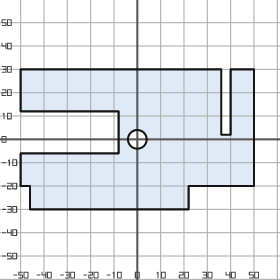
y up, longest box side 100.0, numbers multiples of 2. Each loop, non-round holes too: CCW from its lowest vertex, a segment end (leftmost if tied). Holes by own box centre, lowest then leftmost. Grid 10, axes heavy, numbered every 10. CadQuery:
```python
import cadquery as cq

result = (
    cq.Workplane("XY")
    .moveTo(-46.0, -30.0)
    .lineTo(22.0, -30.0)
    .lineTo(22.0, -20.0)
    .lineTo(50.0, -20.0)
    .lineTo(50.0, 30.0)
    .lineTo(40.0, 30.0)
    .lineTo(40.0, 2.0)
    .lineTo(36.0, 2.0)
    .lineTo(36.0, 30.0)
    .lineTo(-50.0, 30.0)
    .lineTo(-50.0, 12.0)
    .lineTo(-8.0, 12.0)
    .lineTo(-8.0, -6.0)
    .lineTo(-50.0, -6.0)
    .lineTo(-50.0, -20.0)
    .lineTo(-46.0, -20.0)
    .close()
    .moveTo(0.0, 0.0)
    .circle(4.0)
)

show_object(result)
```